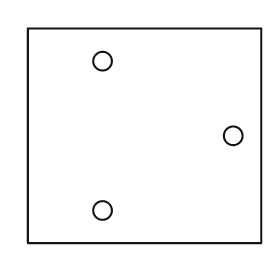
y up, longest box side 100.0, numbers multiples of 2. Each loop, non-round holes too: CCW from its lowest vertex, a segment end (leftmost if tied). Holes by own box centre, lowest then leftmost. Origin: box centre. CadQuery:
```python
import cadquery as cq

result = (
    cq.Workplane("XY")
    .moveTo(-50.0, -46.0)
    .lineTo(50.0, -46.0)
    .lineTo(50.0, 46.0)
    .lineTo(-50.0, 46.0)
    .close()
    .moveTo(-18.0, -32.0)
    .circle(4.0)
    .moveTo(38.0, 0.0)
    .circle(4.0)
    .moveTo(-18.0, 32.0)
    .circle(4.0)
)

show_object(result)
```